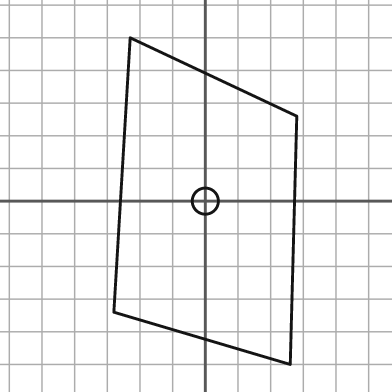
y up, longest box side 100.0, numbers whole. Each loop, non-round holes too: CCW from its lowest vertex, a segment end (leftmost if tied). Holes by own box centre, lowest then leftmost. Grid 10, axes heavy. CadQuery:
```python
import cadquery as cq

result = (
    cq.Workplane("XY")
    .moveTo(26.0, -50.0)
    .lineTo(28.0, 26.0)
    .lineTo(-23.0, 50.0)
    .lineTo(-28.0, -34.0)
    .close()
    .moveTo(0.0, 0.0)
    .circle(4.0)
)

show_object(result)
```